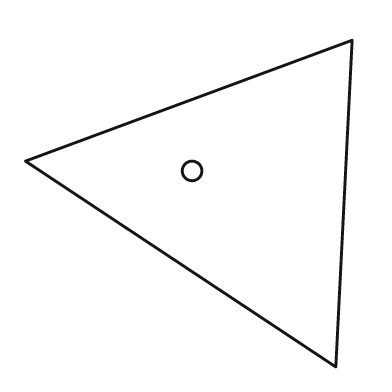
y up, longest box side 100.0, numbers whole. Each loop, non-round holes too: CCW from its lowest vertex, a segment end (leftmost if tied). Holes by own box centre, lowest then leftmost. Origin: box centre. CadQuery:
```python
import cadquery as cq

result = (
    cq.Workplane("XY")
    .moveTo(45.0, -50.0)
    .lineTo(50.0, 50.0)
    .lineTo(-50.0, 13.0)
    .close()
    .moveTo(1.0, 10.0)
    .circle(3.0)
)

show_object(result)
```